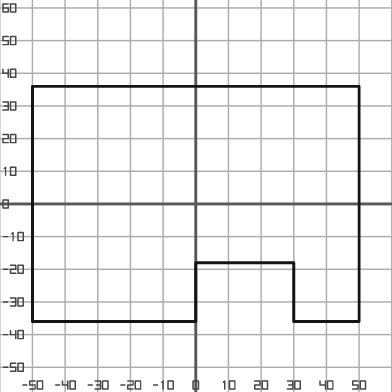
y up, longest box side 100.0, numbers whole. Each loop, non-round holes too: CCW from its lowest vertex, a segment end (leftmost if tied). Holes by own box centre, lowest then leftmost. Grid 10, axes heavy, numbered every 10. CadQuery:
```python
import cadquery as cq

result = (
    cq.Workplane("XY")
    .moveTo(-50.0, -36.0)
    .lineTo(0.0, -36.0)
    .lineTo(0.0, -18.0)
    .lineTo(30.0, -18.0)
    .lineTo(30.0, -36.0)
    .lineTo(50.0, -36.0)
    .lineTo(50.0, 36.0)
    .lineTo(-50.0, 36.0)
    .close()
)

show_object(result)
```